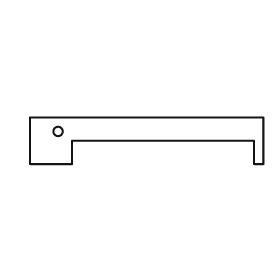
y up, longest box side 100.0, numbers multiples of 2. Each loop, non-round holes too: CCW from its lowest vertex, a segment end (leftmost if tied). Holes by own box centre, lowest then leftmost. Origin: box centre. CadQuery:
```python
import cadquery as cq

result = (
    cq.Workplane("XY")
    .moveTo(-50.0, -10.0)
    .lineTo(-32.0, -10.0)
    .lineTo(-32.0, 0.0)
    .lineTo(46.0, 0.0)
    .lineTo(46.0, -10.0)
    .lineTo(50.0, -10.0)
    .lineTo(50.0, 10.0)
    .lineTo(-50.0, 10.0)
    .close()
    .moveTo(-38.0, 4.0)
    .circle(2.0)
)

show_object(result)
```